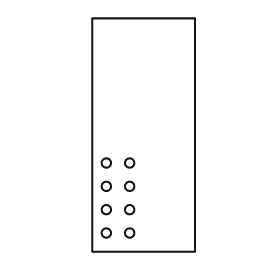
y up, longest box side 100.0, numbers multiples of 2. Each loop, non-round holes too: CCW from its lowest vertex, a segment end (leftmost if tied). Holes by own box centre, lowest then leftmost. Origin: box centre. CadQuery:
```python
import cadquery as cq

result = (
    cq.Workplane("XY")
    .moveTo(-22.0, -50.0)
    .lineTo(22.0, -50.0)
    .lineTo(22.0, 50.0)
    .lineTo(-22.0, 50.0)
    .close()
    .moveTo(-16.0, -42.0)
    .circle(2.0)
    .moveTo(-6.0, -42.0)
    .circle(2.0)
    .moveTo(-16.0, -32.0)
    .circle(2.0)
    .moveTo(-6.0, -32.0)
    .circle(2.0)
    .moveTo(-16.0, -22.0)
    .circle(2.0)
    .moveTo(-6.0, -22.0)
    .circle(2.0)
    .moveTo(-16.0, -12.0)
    .circle(2.0)
    .moveTo(-6.0, -12.0)
    .circle(2.0)
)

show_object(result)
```